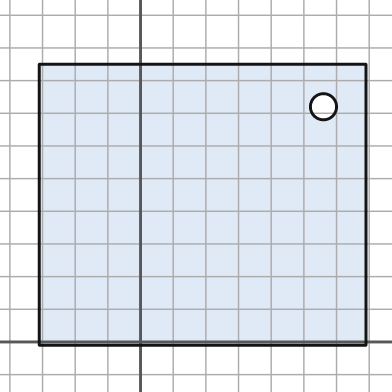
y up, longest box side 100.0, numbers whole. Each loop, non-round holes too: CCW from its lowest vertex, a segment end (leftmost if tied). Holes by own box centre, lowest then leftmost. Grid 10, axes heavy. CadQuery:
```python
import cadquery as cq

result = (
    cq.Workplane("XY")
    .moveTo(-31.0, -1.0)
    .lineTo(69.0, -1.0)
    .lineTo(69.0, 85.0)
    .lineTo(-31.0, 85.0)
    .close()
    .moveTo(56.0, 72.0)
    .circle(4.0)
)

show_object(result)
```